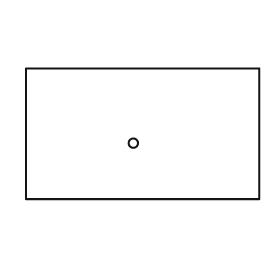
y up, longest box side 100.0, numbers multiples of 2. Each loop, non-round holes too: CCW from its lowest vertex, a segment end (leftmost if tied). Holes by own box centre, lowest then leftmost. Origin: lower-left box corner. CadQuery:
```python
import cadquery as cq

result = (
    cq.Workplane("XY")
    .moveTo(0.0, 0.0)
    .lineTo(100.0, 0.0)
    .lineTo(100.0, 56.0)
    .lineTo(0.0, 56.0)
    .close()
    .moveTo(46.0, 24.0)
    .circle(2.0)
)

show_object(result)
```